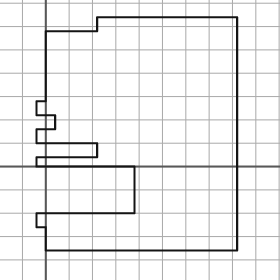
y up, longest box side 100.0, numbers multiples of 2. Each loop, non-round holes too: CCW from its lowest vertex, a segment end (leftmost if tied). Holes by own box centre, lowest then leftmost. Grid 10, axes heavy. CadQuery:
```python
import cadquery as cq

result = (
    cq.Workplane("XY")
    .moveTo(0.0, -36.0)
    .lineTo(82.0, -36.0)
    .lineTo(82.0, 64.0)
    .lineTo(22.0, 64.0)
    .lineTo(22.0, 58.0)
    .lineTo(0.0, 58.0)
    .lineTo(0.0, 28.0)
    .lineTo(-4.0, 28.0)
    .lineTo(-4.0, 22.0)
    .lineTo(4.0, 22.0)
    .lineTo(4.0, 16.0)
    .lineTo(-4.0, 16.0)
    .lineTo(-4.0, 10.0)
    .lineTo(22.0, 10.0)
    .lineTo(22.0, 4.0)
    .lineTo(-4.0, 4.0)
    .lineTo(-4.0, 0.0)
    .lineTo(38.0, 0.0)
    .lineTo(38.0, -20.0)
    .lineTo(-4.0, -20.0)
    .lineTo(-4.0, -26.0)
    .lineTo(0.0, -26.0)
    .close()
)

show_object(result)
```